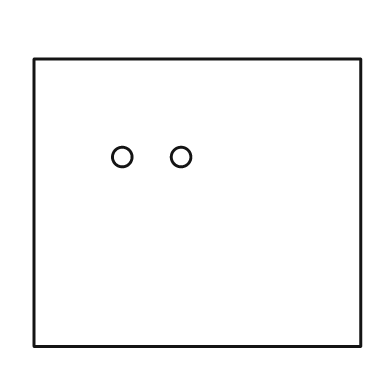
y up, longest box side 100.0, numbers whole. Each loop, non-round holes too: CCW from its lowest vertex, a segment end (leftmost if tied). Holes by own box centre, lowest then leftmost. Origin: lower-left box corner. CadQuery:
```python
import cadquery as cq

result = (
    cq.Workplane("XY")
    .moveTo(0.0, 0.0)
    .lineTo(100.0, 0.0)
    .lineTo(100.0, 88.0)
    .lineTo(0.0, 88.0)
    .close()
    .moveTo(27.0, 58.0)
    .circle(3.0)
    .moveTo(45.0, 58.0)
    .circle(3.0)
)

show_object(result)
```